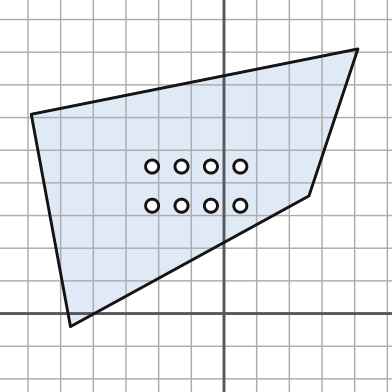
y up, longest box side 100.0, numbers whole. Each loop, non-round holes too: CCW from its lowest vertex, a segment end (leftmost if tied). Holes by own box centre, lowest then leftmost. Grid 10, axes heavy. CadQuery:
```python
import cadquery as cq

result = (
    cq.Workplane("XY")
    .moveTo(-47.0, -4.0)
    .lineTo(26.0, 36.0)
    .lineTo(41.0, 81.0)
    .lineTo(-59.0, 61.0)
    .close()
    .moveTo(-22.0, 33.0)
    .circle(2.0)
    .moveTo(-13.0, 33.0)
    .circle(2.0)
    .moveTo(-4.0, 33.0)
    .circle(2.0)
    .moveTo(5.0, 33.0)
    .circle(2.0)
    .moveTo(-22.0, 45.0)
    .circle(2.0)
    .moveTo(-13.0, 45.0)
    .circle(2.0)
    .moveTo(-4.0, 45.0)
    .circle(2.0)
    .moveTo(5.0, 45.0)
    .circle(2.0)
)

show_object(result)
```